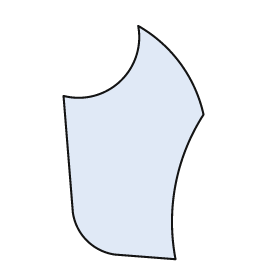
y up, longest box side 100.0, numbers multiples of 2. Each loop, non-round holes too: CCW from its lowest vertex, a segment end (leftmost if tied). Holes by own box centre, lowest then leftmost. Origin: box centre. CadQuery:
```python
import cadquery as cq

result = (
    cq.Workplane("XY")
    .moveTo(18.0, -50.0)
    .threePointArc((18.0, -18.0), (30.0, 12.0))
    .threePointArc((20.0, 34.0), (2.0, 50.0))
    .threePointArc((-6.0, 26.0), (-30.0, 20.0))
    .lineTo(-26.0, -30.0)
    .threePointArc((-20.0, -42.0), (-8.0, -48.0))
    .close()
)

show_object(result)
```